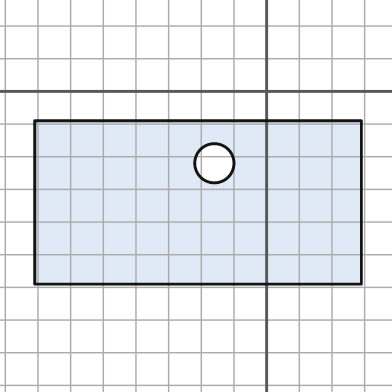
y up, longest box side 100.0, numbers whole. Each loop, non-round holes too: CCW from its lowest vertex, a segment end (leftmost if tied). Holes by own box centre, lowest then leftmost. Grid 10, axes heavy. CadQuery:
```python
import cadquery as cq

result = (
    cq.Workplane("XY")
    .moveTo(-71.0, -59.0)
    .lineTo(29.0, -59.0)
    .lineTo(29.0, -9.0)
    .lineTo(-71.0, -9.0)
    .close()
    .moveTo(-16.0, -22.0)
    .circle(6.0)
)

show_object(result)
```